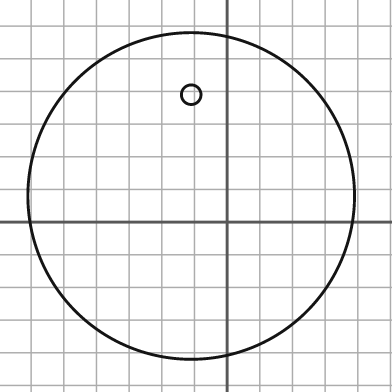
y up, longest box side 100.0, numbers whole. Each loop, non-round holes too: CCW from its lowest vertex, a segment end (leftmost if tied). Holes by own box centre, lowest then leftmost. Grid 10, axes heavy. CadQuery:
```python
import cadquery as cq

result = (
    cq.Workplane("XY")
    .moveTo(-11.0, 8.0)
    .circle(50.0)
    .moveTo(-11.0, 39.0)
    .circle(3.0)
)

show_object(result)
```